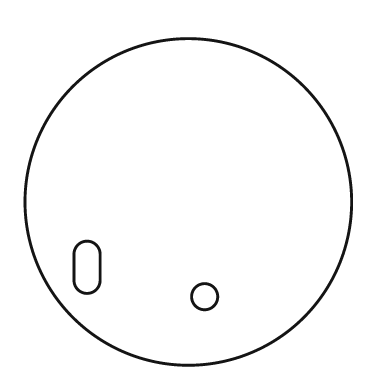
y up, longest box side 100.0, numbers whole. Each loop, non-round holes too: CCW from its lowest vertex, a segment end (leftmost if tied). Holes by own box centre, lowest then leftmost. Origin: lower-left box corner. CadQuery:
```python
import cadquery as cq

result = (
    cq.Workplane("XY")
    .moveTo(50.0, 50.0)
    .circle(50.0)
    .moveTo(55.0, 21.0)
    .circle(4.0)
    .moveTo(15.0, 26.0)
    .threePointArc((19.0, 22.0), (23.0, 26.0))
    .lineTo(23.0, 34.0)
    .threePointArc((19.0, 38.0), (15.0, 34.0))
    .close()
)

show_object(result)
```